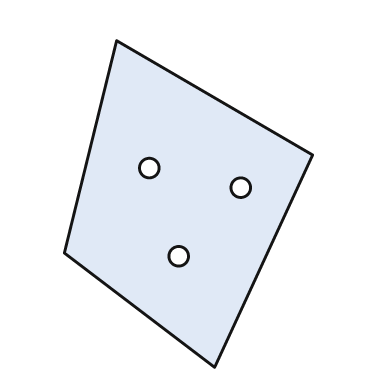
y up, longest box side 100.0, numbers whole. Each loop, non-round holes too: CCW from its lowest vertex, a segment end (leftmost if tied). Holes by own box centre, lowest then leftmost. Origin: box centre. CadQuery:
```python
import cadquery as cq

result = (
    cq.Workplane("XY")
    .moveTo(8.0, -50.0)
    .lineTo(38.0, 15.0)
    .lineTo(-22.0, 50.0)
    .lineTo(-38.0, -15.0)
    .close()
    .moveTo(-3.0, -16.0)
    .circle(3.0)
    .moveTo(16.0, 5.0)
    .circle(3.0)
    .moveTo(-12.0, 11.0)
    .circle(3.0)
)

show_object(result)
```